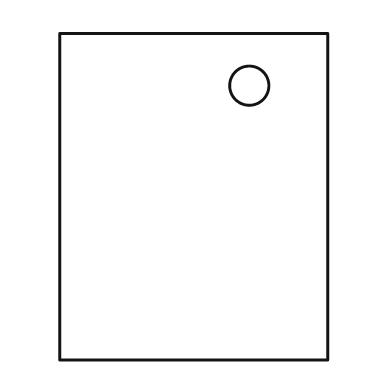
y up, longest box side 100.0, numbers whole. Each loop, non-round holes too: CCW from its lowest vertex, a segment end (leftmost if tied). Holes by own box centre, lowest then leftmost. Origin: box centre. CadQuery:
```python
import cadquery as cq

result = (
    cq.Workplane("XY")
    .moveTo(-41.0, -50.0)
    .lineTo(41.0, -50.0)
    .lineTo(41.0, 50.0)
    .lineTo(-41.0, 50.0)
    .close()
    .moveTo(17.0, 34.0)
    .circle(6.0)
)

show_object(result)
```